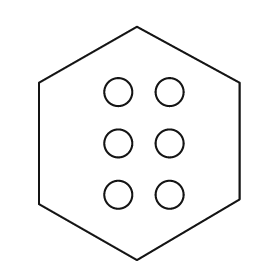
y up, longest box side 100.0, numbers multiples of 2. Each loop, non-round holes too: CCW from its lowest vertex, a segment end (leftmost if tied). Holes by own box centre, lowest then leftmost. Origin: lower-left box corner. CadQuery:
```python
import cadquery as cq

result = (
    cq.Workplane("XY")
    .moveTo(42.0, 0.0)
    .lineTo(86.0, 26.0)
    .lineTo(86.0, 76.0)
    .lineTo(42.0, 100.0)
    .lineTo(0.0, 76.0)
    .lineTo(0.0, 24.0)
    .close()
    .moveTo(34.0, 28.0)
    .circle(6.0)
    .moveTo(56.0, 28.0)
    .circle(6.0)
    .moveTo(34.0, 50.0)
    .circle(6.0)
    .moveTo(56.0, 50.0)
    .circle(6.0)
    .moveTo(34.0, 72.0)
    .circle(6.0)
    .moveTo(56.0, 72.0)
    .circle(6.0)
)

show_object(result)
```